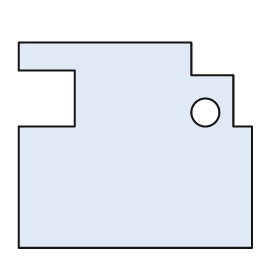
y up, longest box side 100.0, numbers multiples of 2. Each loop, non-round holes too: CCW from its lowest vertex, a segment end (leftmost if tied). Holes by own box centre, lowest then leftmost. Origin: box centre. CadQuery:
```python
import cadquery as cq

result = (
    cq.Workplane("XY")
    .moveTo(-50.0, -44.0)
    .lineTo(50.0, -44.0)
    .lineTo(50.0, 8.0)
    .lineTo(42.0, 8.0)
    .lineTo(42.0, 30.0)
    .lineTo(24.0, 30.0)
    .lineTo(24.0, 44.0)
    .lineTo(-50.0, 44.0)
    .lineTo(-50.0, 32.0)
    .lineTo(-26.0, 32.0)
    .lineTo(-26.0, 8.0)
    .lineTo(-50.0, 8.0)
    .close()
    .moveTo(30.0, 14.0)
    .circle(6.0)
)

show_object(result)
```